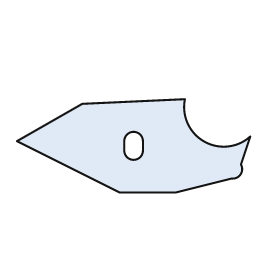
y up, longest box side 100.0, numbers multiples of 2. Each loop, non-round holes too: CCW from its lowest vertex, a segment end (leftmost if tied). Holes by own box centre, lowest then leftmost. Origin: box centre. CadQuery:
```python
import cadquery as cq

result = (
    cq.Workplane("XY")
    .moveTo(-6.0, -20.0)
    .lineTo(18.0, -20.0)
    .lineTo(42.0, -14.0)
    .threePointArc((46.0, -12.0), (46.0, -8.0))
    .lineTo(50.0, 4.0)
    .threePointArc((30.0, 2.0), (22.0, 20.0))
    .lineTo(-22.0, 18.0)
    .lineTo(-50.0, 2.0)
    .close()
    .moveTo(-4.0, -2.0)
    .threePointArc((0.0, -6.0), (4.0, -2.0))
    .lineTo(4.0, 2.0)
    .threePointArc((0.0, 6.0), (-4.0, 2.0))
    .close()
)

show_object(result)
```